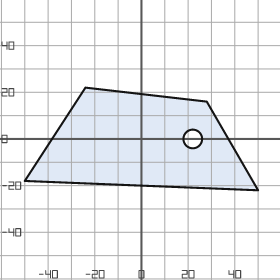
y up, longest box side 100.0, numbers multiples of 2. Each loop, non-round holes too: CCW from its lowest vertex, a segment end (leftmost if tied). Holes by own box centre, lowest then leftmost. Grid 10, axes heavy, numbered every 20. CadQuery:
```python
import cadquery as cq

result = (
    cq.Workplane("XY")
    .moveTo(50.0, -22.0)
    .lineTo(28.0, 16.0)
    .lineTo(-24.0, 22.0)
    .lineTo(-50.0, -18.0)
    .close()
    .moveTo(22.0, 0.0)
    .circle(4.0)
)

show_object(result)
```